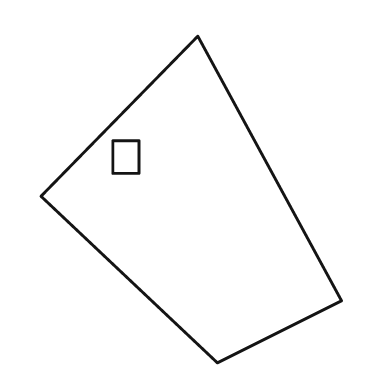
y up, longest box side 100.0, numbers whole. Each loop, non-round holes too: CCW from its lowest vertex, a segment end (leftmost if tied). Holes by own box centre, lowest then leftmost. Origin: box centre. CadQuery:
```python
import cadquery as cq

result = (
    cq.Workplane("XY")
    .moveTo(8.0, -50.0)
    .lineTo(46.0, -31.0)
    .lineTo(2.0, 50.0)
    .lineTo(-46.0, 1.0)
    .close()
    .moveTo(-24.0, 8.0)
    .lineTo(-16.0, 8.0)
    .lineTo(-16.0, 18.0)
    .lineTo(-24.0, 18.0)
    .close()
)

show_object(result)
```